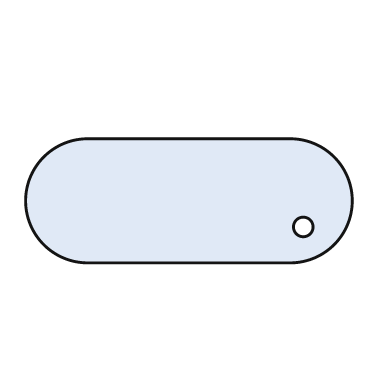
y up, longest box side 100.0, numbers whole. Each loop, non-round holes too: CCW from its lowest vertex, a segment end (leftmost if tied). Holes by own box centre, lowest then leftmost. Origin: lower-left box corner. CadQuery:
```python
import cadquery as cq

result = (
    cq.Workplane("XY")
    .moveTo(19.0, 0.0)
    .lineTo(81.0, 0.0)
    .threePointArc((100.0, 19.0), (81.0, 38.0))
    .lineTo(19.0, 38.0)
    .threePointArc((0.0, 19.0), (19.0, 0.0))
    .close()
    .moveTo(85.0, 11.0)
    .circle(3.0)
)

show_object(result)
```